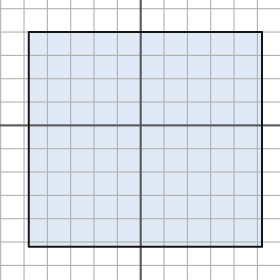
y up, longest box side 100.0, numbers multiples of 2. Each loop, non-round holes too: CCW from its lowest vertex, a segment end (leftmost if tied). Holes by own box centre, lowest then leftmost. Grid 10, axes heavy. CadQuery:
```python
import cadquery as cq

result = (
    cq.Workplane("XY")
    .moveTo(-48.0, -52.0)
    .lineTo(52.0, -52.0)
    .lineTo(52.0, 40.0)
    .lineTo(-48.0, 40.0)
    .close()
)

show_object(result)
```